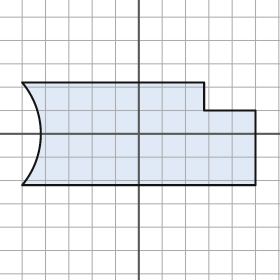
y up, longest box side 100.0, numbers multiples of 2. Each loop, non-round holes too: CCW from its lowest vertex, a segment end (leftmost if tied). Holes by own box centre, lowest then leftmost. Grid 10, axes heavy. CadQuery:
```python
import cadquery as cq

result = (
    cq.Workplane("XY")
    .moveTo(-50.0, -22.0)
    .lineTo(50.0, -22.0)
    .lineTo(50.0, 10.0)
    .lineTo(28.0, 10.0)
    .lineTo(28.0, 22.0)
    .lineTo(-50.0, 22.0)
    .threePointArc((-42.0, 0.0), (-50.0, -22.0))
    .close()
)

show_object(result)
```